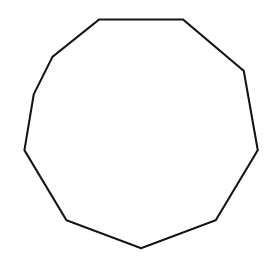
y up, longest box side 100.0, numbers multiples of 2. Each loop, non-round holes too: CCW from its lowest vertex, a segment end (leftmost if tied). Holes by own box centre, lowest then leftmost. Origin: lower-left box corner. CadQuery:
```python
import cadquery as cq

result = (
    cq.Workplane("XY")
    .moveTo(50.0, 0.0)
    .lineTo(82.0, 12.0)
    .lineTo(100.0, 42.0)
    .lineTo(94.0, 76.0)
    .lineTo(68.0, 98.0)
    .lineTo(32.0, 98.0)
    .lineTo(12.0, 82.0)
    .lineTo(4.0, 66.0)
    .lineTo(0.0, 42.0)
    .lineTo(18.0, 12.0)
    .close()
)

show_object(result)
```